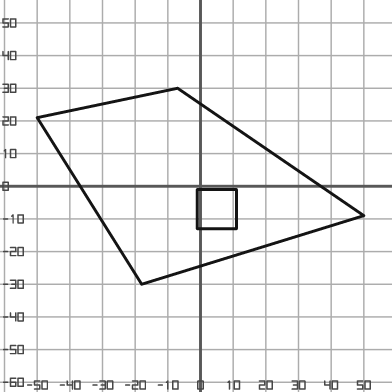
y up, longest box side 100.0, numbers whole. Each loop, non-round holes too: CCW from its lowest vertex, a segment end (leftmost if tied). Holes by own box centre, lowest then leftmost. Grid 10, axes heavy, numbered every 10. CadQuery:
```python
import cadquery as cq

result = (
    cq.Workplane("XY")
    .moveTo(-18.0, -30.0)
    .lineTo(50.0, -9.0)
    .lineTo(-7.0, 30.0)
    .lineTo(-50.0, 21.0)
    .close()
    .moveTo(-1.0, -13.0)
    .lineTo(11.0, -13.0)
    .lineTo(11.0, -1.0)
    .lineTo(-1.0, -1.0)
    .close()
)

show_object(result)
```